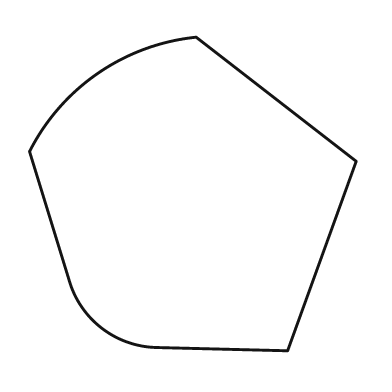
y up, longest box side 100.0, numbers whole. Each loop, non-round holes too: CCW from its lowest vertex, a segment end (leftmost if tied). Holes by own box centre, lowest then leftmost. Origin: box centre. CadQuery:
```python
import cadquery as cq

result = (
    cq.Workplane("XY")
    .moveTo(29.0, -48.0)
    .lineTo(50.0, 10.0)
    .lineTo(1.0, 48.0)
    .threePointArc((-29.0, 37.0), (-50.0, 13.0))
    .lineTo(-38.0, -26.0)
    .threePointArc((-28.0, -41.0), (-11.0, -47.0))
    .close()
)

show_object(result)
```